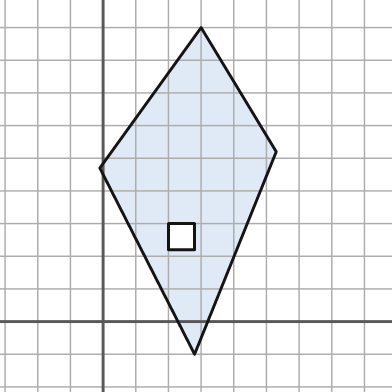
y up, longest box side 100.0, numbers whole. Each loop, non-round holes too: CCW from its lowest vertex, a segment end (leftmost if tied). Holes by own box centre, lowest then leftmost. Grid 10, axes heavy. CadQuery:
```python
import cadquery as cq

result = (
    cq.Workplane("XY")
    .moveTo(28.0, -10.0)
    .lineTo(53.0, 52.0)
    .lineTo(30.0, 90.0)
    .lineTo(-1.0, 47.0)
    .close()
    .moveTo(20.0, 22.0)
    .lineTo(28.0, 22.0)
    .lineTo(28.0, 30.0)
    .lineTo(20.0, 30.0)
    .close()
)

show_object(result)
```